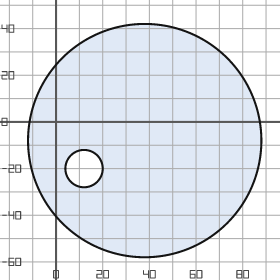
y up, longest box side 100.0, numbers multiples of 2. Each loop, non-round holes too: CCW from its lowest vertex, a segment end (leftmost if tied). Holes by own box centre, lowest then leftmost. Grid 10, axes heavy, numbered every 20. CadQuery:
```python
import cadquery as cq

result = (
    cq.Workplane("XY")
    .moveTo(38.0, -8.0)
    .circle(50.0)
    .moveTo(12.0, -20.0)
    .circle(8.0)
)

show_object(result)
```